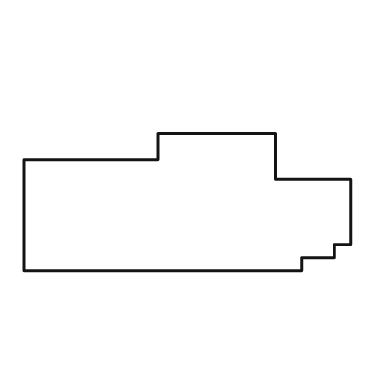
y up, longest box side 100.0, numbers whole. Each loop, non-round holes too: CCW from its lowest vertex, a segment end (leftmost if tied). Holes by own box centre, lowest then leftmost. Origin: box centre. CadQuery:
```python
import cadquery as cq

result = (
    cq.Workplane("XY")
    .moveTo(-50.0, -21.0)
    .lineTo(35.0, -21.0)
    .lineTo(35.0, -17.0)
    .lineTo(45.0, -17.0)
    .lineTo(45.0, -13.0)
    .lineTo(50.0, -13.0)
    .lineTo(50.0, 7.0)
    .lineTo(27.0, 7.0)
    .lineTo(27.0, 21.0)
    .lineTo(-9.0, 21.0)
    .lineTo(-9.0, 13.0)
    .lineTo(-50.0, 13.0)
    .close()
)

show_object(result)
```